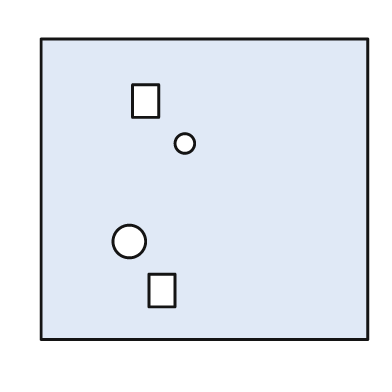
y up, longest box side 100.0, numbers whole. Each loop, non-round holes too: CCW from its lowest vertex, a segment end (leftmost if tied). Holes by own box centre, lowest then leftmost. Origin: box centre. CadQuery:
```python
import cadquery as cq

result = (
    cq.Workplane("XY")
    .moveTo(-50.0, -46.0)
    .lineTo(50.0, -46.0)
    .lineTo(50.0, 46.0)
    .lineTo(-50.0, 46.0)
    .close()
    .moveTo(-17.0, -36.0)
    .lineTo(-9.0, -36.0)
    .lineTo(-9.0, -26.0)
    .lineTo(-17.0, -26.0)
    .close()
    .moveTo(-23.0, -16.0)
    .circle(5.0)
    .moveTo(-6.0, 14.0)
    .circle(3.0)
    .moveTo(-22.0, 22.0)
    .lineTo(-14.0, 22.0)
    .lineTo(-14.0, 32.0)
    .lineTo(-22.0, 32.0)
    .close()
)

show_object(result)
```